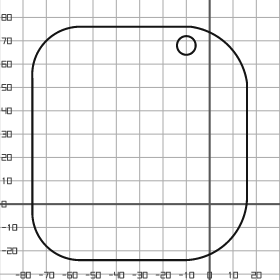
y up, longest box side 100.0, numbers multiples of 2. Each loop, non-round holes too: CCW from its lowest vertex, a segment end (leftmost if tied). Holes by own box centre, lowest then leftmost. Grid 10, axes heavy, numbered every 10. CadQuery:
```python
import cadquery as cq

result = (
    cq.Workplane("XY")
    .moveTo(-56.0, -24.0)
    .lineTo(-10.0, -24.0)
    .threePointArc((8.0, -16.0), (16.0, 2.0))
    .lineTo(16.0, 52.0)
    .threePointArc((8.0, 68.0), (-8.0, 76.0))
    .lineTo(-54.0, 76.0)
    .threePointArc((-70.0, 70.0), (-76.0, 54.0))
    .lineTo(-76.0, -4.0)
    .threePointArc((-70.0, -18.0), (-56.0, -24.0))
    .close()
    .moveTo(-10.0, 68.0)
    .circle(4.0)
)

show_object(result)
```